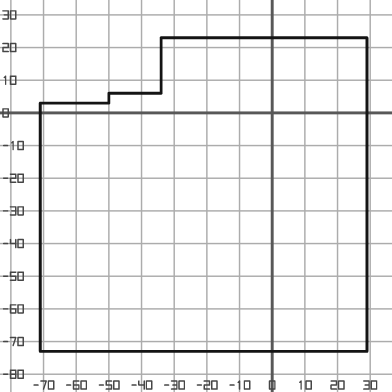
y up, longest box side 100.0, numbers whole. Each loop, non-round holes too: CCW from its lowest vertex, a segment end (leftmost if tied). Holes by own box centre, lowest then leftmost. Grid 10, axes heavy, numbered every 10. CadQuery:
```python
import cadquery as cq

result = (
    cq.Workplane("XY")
    .moveTo(-71.0, -73.0)
    .lineTo(29.0, -73.0)
    .lineTo(29.0, 23.0)
    .lineTo(-34.0, 23.0)
    .lineTo(-34.0, 6.0)
    .lineTo(-50.0, 6.0)
    .lineTo(-50.0, 3.0)
    .lineTo(-71.0, 3.0)
    .close()
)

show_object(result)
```